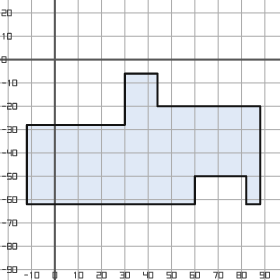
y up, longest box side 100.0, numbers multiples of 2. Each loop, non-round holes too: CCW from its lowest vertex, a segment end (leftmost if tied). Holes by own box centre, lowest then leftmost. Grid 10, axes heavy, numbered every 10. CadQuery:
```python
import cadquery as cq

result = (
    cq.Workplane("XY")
    .moveTo(-12.0, -62.0)
    .lineTo(60.0, -62.0)
    .lineTo(60.0, -50.0)
    .lineTo(82.0, -50.0)
    .lineTo(82.0, -62.0)
    .lineTo(88.0, -62.0)
    .lineTo(88.0, -20.0)
    .lineTo(44.0, -20.0)
    .lineTo(44.0, -6.0)
    .lineTo(30.0, -6.0)
    .lineTo(30.0, -28.0)
    .lineTo(-12.0, -28.0)
    .close()
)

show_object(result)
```